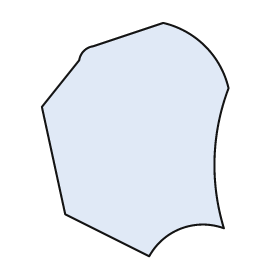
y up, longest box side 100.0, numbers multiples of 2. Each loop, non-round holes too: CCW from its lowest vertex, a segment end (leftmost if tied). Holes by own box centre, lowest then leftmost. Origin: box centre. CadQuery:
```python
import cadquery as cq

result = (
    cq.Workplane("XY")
    .moveTo(6.0, -50.0)
    .threePointArc((20.0, -38.0), (38.0, -38.0))
    .threePointArc((34.0, -8.0), (40.0, 22.0))
    .threePointArc((30.0, 40.0), (12.0, 50.0))
    .lineTo(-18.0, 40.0)
    .threePointArc((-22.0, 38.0), (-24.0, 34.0))
    .lineTo(-40.0, 14.0)
    .lineTo(-30.0, -32.0)
    .close()
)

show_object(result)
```